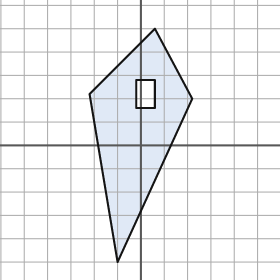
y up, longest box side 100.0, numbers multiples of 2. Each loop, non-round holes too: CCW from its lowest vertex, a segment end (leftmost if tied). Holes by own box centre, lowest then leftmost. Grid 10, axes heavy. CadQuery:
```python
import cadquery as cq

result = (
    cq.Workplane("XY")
    .moveTo(-10.0, -50.0)
    .lineTo(22.0, 20.0)
    .lineTo(6.0, 50.0)
    .lineTo(-22.0, 22.0)
    .close()
    .moveTo(-2.0, 16.0)
    .lineTo(6.0, 16.0)
    .lineTo(6.0, 28.0)
    .lineTo(-2.0, 28.0)
    .close()
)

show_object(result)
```